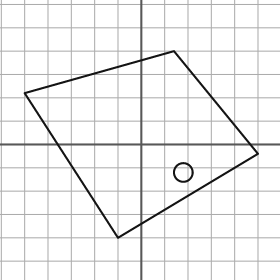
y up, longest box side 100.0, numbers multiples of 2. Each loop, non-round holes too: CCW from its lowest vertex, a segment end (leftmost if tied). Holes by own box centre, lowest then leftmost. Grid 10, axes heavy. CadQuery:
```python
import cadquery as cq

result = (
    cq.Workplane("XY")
    .moveTo(-10.0, -40.0)
    .lineTo(50.0, -4.0)
    .lineTo(14.0, 40.0)
    .lineTo(-50.0, 22.0)
    .close()
    .moveTo(18.0, -12.0)
    .circle(4.0)
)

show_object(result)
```